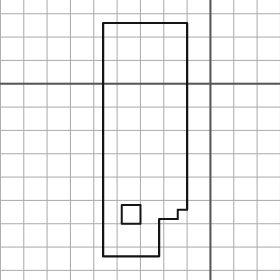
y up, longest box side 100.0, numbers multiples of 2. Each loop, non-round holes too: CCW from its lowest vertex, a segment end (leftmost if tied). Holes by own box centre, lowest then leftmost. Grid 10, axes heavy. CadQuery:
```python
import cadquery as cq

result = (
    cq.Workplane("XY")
    .moveTo(-46.0, -74.0)
    .lineTo(-22.0, -74.0)
    .lineTo(-22.0, -58.0)
    .lineTo(-14.0, -58.0)
    .lineTo(-14.0, -54.0)
    .lineTo(-10.0, -54.0)
    .lineTo(-10.0, 26.0)
    .lineTo(-46.0, 26.0)
    .close()
    .moveTo(-38.0, -60.0)
    .lineTo(-30.0, -60.0)
    .lineTo(-30.0, -52.0)
    .lineTo(-38.0, -52.0)
    .close()
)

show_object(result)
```